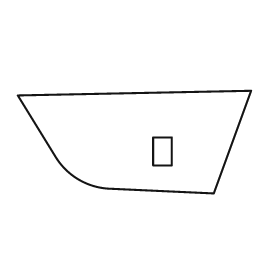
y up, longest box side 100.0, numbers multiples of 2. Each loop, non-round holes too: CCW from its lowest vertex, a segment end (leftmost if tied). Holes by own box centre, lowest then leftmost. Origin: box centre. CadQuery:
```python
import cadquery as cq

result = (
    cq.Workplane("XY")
    .moveTo(34.0, -22.0)
    .lineTo(50.0, 22.0)
    .lineTo(-50.0, 20.0)
    .lineTo(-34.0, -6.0)
    .threePointArc((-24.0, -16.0), (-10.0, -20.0))
    .close()
    .moveTo(8.0, -10.0)
    .lineTo(16.0, -10.0)
    .lineTo(16.0, 2.0)
    .lineTo(8.0, 2.0)
    .close()
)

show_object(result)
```